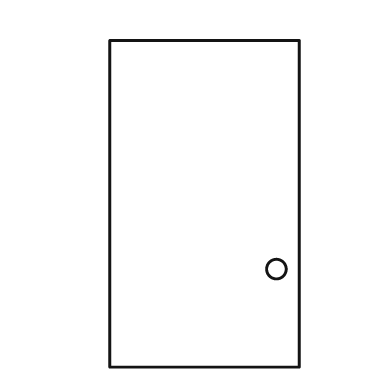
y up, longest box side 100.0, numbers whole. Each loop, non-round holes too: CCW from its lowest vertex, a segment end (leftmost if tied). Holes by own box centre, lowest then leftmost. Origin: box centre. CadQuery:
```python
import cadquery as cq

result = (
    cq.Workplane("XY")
    .moveTo(-29.0, -50.0)
    .lineTo(29.0, -50.0)
    .lineTo(29.0, 50.0)
    .lineTo(-29.0, 50.0)
    .close()
    .moveTo(22.0, -20.0)
    .circle(3.0)
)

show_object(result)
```